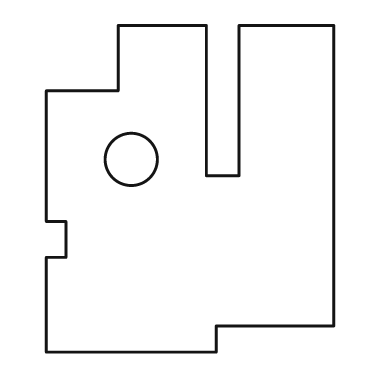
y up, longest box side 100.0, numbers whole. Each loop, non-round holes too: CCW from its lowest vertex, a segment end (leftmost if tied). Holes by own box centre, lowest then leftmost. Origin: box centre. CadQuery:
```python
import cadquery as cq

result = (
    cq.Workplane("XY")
    .moveTo(-44.0, -50.0)
    .lineTo(8.0, -50.0)
    .lineTo(8.0, -42.0)
    .lineTo(44.0, -42.0)
    .lineTo(44.0, 50.0)
    .lineTo(15.0, 50.0)
    .lineTo(15.0, 4.0)
    .lineTo(5.0, 4.0)
    .lineTo(5.0, 50.0)
    .lineTo(-22.0, 50.0)
    .lineTo(-22.0, 30.0)
    .lineTo(-44.0, 30.0)
    .lineTo(-44.0, -10.0)
    .lineTo(-38.0, -10.0)
    .lineTo(-38.0, -21.0)
    .lineTo(-44.0, -21.0)
    .close()
    .moveTo(-18.0, 9.0)
    .circle(8.0)
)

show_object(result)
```